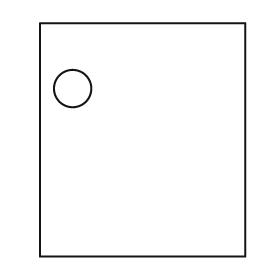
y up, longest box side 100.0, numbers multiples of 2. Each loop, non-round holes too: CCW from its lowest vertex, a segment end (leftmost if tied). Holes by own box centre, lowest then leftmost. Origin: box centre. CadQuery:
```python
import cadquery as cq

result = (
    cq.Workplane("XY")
    .moveTo(-44.0, -50.0)
    .lineTo(44.0, -50.0)
    .lineTo(44.0, 50.0)
    .lineTo(-44.0, 50.0)
    .close()
    .moveTo(-30.0, 22.0)
    .circle(8.0)
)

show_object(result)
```